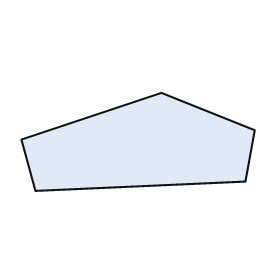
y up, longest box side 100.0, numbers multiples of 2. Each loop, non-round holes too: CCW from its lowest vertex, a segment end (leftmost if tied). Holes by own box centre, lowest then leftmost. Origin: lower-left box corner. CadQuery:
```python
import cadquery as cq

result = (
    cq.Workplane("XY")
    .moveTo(6.0, 0.0)
    .lineTo(96.0, 4.0)
    .lineTo(100.0, 26.0)
    .lineTo(60.0, 42.0)
    .lineTo(0.0, 22.0)
    .close()
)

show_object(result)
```